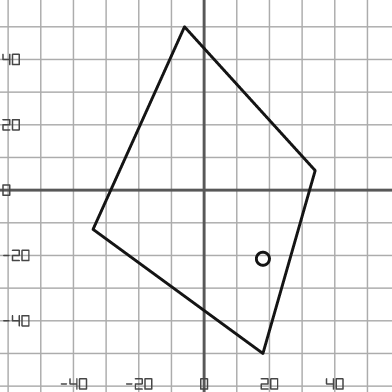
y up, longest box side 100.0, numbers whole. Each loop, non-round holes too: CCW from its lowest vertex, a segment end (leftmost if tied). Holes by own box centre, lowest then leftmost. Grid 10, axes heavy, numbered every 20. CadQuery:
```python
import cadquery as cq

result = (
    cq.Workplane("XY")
    .moveTo(18.0, -50.0)
    .lineTo(34.0, 6.0)
    .lineTo(-6.0, 50.0)
    .lineTo(-34.0, -12.0)
    .close()
    .moveTo(18.0, -21.0)
    .circle(2.0)
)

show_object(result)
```